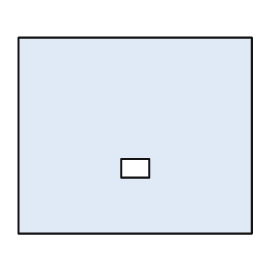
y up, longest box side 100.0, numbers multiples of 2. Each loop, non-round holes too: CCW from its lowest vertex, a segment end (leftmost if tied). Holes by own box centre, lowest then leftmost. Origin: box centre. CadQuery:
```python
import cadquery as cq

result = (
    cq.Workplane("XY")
    .moveTo(-50.0, -42.0)
    .lineTo(50.0, -42.0)
    .lineTo(50.0, 42.0)
    .lineTo(-50.0, 42.0)
    .close()
    .moveTo(-6.0, -18.0)
    .lineTo(6.0, -18.0)
    .lineTo(6.0, -10.0)
    .lineTo(-6.0, -10.0)
    .close()
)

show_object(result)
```